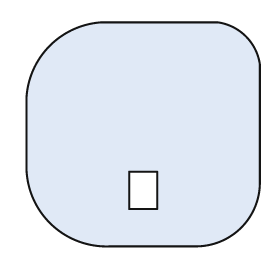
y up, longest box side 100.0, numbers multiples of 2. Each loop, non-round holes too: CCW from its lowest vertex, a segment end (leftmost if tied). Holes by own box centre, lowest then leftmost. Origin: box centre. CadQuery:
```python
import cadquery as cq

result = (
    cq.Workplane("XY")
    .moveTo(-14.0, -48.0)
    .lineTo(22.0, -48.0)
    .threePointArc((42.0, -40.0), (50.0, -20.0))
    .lineTo(50.0, 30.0)
    .threePointArc((44.0, 42.0), (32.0, 48.0))
    .lineTo(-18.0, 48.0)
    .threePointArc((-40.0, 38.0), (-50.0, 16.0))
    .lineTo(-50.0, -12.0)
    .threePointArc((-40.0, -38.0), (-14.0, -48.0))
    .close()
    .moveTo(-6.0, -32.0)
    .lineTo(6.0, -32.0)
    .lineTo(6.0, -16.0)
    .lineTo(-6.0, -16.0)
    .close()
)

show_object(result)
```